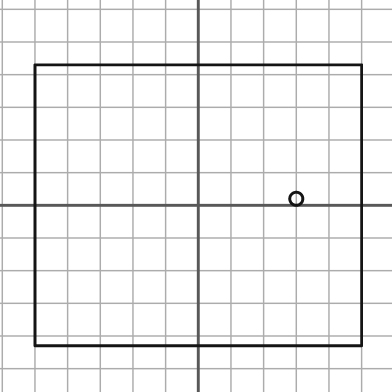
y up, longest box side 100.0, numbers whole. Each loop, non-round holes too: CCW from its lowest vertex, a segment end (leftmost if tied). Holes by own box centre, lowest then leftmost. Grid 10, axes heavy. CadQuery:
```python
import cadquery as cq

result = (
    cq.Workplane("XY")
    .moveTo(-50.0, -43.0)
    .lineTo(50.0, -43.0)
    .lineTo(50.0, 43.0)
    .lineTo(-50.0, 43.0)
    .close()
    .moveTo(30.0, 2.0)
    .circle(2.0)
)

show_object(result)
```